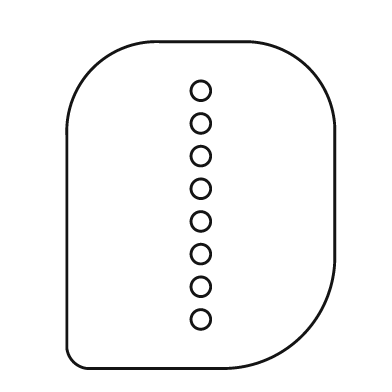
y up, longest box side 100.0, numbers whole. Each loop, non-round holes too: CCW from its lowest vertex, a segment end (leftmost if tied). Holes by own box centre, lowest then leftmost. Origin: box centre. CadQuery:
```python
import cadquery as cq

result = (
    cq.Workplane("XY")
    .moveTo(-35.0, -50.0)
    .lineTo(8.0, -50.0)
    .threePointArc((31.0, -40.0), (41.0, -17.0))
    .lineTo(41.0, 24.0)
    .threePointArc((33.0, 42.0), (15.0, 50.0))
    .lineTo(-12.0, 50.0)
    .threePointArc((-33.0, 42.0), (-41.0, 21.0))
    .lineTo(-41.0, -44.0)
    .threePointArc((-39.0, -48.0), (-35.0, -50.0))
    .close()
    .moveTo(0.0, -35.0)
    .circle(3.0)
    .moveTo(0.0, -25.0)
    .circle(3.0)
    .moveTo(0.0, -15.0)
    .circle(3.0)
    .moveTo(0.0, -5.0)
    .circle(3.0)
    .moveTo(0.0, 5.0)
    .circle(3.0)
    .moveTo(0.0, 15.0)
    .circle(3.0)
    .moveTo(0.0, 25.0)
    .circle(3.0)
    .moveTo(0.0, 35.0)
    .circle(3.0)
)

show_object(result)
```